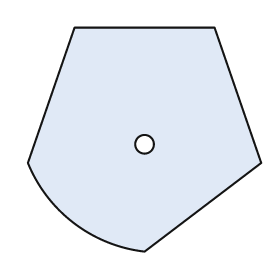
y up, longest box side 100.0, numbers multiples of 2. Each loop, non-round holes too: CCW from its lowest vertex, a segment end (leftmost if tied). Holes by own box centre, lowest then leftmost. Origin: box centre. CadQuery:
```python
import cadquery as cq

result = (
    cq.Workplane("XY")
    .moveTo(0.0, -48.0)
    .lineTo(50.0, -10.0)
    .lineTo(30.0, 48.0)
    .lineTo(-30.0, 48.0)
    .lineTo(-50.0, -10.0)
    .threePointArc((-30.0, -36.0), (0.0, -48.0))
    .close()
    .moveTo(0.0, -2.0)
    .circle(4.0)
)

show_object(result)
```